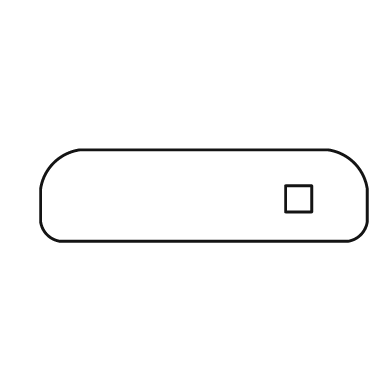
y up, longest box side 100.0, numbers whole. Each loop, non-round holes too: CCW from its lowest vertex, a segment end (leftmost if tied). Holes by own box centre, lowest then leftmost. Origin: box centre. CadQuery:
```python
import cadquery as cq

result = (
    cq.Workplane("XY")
    .moveTo(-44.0, -14.0)
    .lineTo(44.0, -14.0)
    .threePointArc((48.0, -12.0), (50.0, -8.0))
    .lineTo(50.0, 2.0)
    .threePointArc((46.0, 10.0), (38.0, 14.0))
    .lineTo(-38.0, 14.0)
    .threePointArc((-46.0, 10.0), (-50.0, 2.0))
    .lineTo(-50.0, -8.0)
    .threePointArc((-48.0, -12.0), (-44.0, -14.0))
    .close()
    .moveTo(25.0, -5.0)
    .lineTo(33.0, -5.0)
    .lineTo(33.0, 3.0)
    .lineTo(25.0, 3.0)
    .close()
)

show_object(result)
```